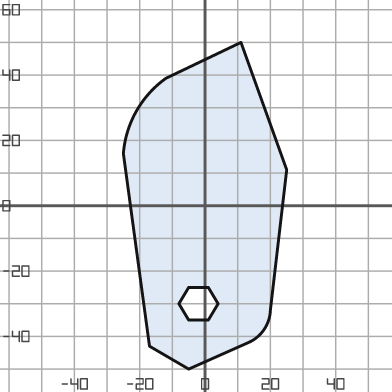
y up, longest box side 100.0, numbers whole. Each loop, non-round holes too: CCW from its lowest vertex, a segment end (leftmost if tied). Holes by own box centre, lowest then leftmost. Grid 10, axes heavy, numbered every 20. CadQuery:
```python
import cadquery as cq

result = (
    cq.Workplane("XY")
    .moveTo(-5.0, -50.0)
    .lineTo(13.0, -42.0)
    .threePointArc((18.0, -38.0), (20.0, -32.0))
    .lineTo(25.0, 11.0)
    .lineTo(11.0, 50.0)
    .lineTo(-12.0, 39.0)
    .threePointArc((-21.0, 29.0), (-25.0, 16.0))
    .lineTo(-17.0, -43.0)
    .close()
    .moveTo(-5.0, -35.0)
    .lineTo(1.0, -35.0)
    .lineTo(4.0, -30.0)
    .lineTo(1.0, -25.0)
    .lineTo(-5.0, -25.0)
    .lineTo(-8.0, -30.0)
    .close()
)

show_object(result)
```